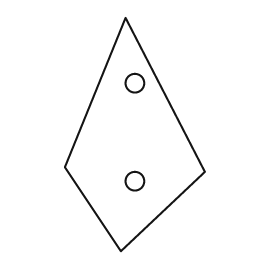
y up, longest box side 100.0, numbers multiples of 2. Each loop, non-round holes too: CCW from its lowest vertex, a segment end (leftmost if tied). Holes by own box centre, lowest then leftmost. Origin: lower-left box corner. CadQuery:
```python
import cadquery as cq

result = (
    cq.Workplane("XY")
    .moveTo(24.0, 0.0)
    .lineTo(60.0, 34.0)
    .lineTo(26.0, 100.0)
    .lineTo(0.0, 36.0)
    .close()
    .moveTo(30.0, 30.0)
    .circle(4.0)
    .moveTo(30.0, 72.0)
    .circle(4.0)
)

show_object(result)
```